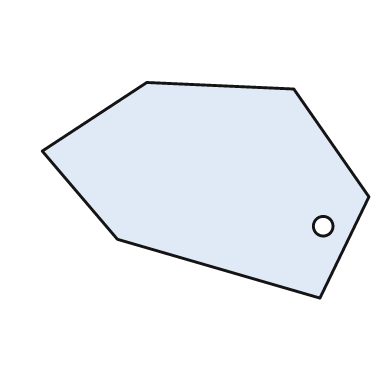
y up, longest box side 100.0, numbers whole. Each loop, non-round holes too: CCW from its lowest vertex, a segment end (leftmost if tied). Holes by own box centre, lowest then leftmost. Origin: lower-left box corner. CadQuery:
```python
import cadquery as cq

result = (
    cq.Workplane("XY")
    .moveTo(85.0, 0.0)
    .lineTo(100.0, 31.0)
    .lineTo(77.0, 64.0)
    .lineTo(32.0, 66.0)
    .lineTo(0.0, 45.0)
    .lineTo(23.0, 18.0)
    .close()
    .moveTo(86.0, 22.0)
    .circle(3.0)
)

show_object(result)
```